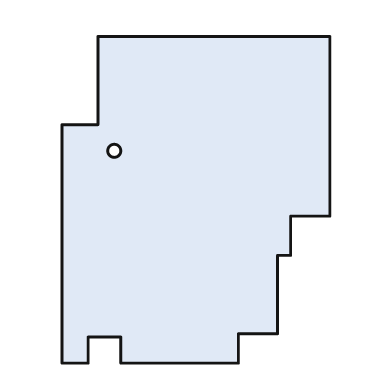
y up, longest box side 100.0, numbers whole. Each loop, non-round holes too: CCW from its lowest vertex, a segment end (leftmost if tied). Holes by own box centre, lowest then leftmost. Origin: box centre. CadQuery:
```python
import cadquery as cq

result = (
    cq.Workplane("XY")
    .moveTo(-41.0, -50.0)
    .lineTo(-33.0, -50.0)
    .lineTo(-33.0, -42.0)
    .lineTo(-23.0, -42.0)
    .lineTo(-23.0, -50.0)
    .lineTo(13.0, -50.0)
    .lineTo(13.0, -41.0)
    .lineTo(25.0, -41.0)
    .lineTo(25.0, -17.0)
    .lineTo(29.0, -17.0)
    .lineTo(29.0, -5.0)
    .lineTo(41.0, -5.0)
    .lineTo(41.0, 50.0)
    .lineTo(-30.0, 50.0)
    .lineTo(-30.0, 23.0)
    .lineTo(-41.0, 23.0)
    .close()
    .moveTo(-25.0, 15.0)
    .circle(2.0)
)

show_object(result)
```